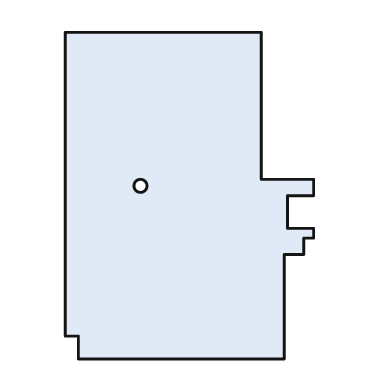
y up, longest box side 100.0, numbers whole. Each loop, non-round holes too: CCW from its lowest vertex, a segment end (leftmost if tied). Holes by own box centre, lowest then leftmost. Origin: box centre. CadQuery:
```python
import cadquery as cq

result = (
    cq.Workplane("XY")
    .moveTo(-34.0, -50.0)
    .lineTo(29.0, -50.0)
    .lineTo(29.0, -18.0)
    .lineTo(35.0, -18.0)
    .lineTo(35.0, -13.0)
    .lineTo(38.0, -13.0)
    .lineTo(38.0, -10.0)
    .lineTo(30.0, -10.0)
    .lineTo(30.0, 0.0)
    .lineTo(38.0, 0.0)
    .lineTo(38.0, 5.0)
    .lineTo(22.0, 5.0)
    .lineTo(22.0, 50.0)
    .lineTo(-38.0, 50.0)
    .lineTo(-38.0, -43.0)
    .lineTo(-34.0, -43.0)
    .close()
    .moveTo(-15.0, 3.0)
    .circle(2.0)
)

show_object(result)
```